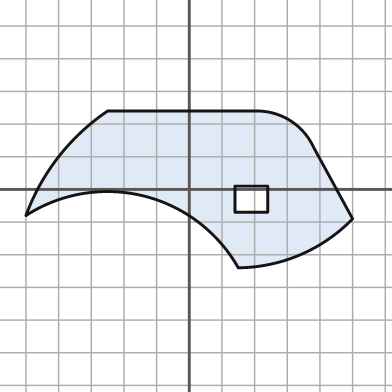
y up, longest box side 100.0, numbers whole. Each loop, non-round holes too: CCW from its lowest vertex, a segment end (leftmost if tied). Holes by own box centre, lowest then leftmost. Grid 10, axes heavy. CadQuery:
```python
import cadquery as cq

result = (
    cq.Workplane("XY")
    .moveTo(15.0, -24.0)
    .threePointArc((34.0, -20.0), (50.0, -9.0))
    .lineTo(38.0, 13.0)
    .threePointArc((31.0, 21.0), (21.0, 24.0))
    .lineTo(-25.0, 24.0)
    .threePointArc((-40.0, 10.0), (-50.0, -8.0))
    .threePointArc((-14.0, -2.0), (15.0, -24.0))
    .close()
    .moveTo(14.0, -7.0)
    .lineTo(24.0, -7.0)
    .lineTo(24.0, 1.0)
    .lineTo(14.0, 1.0)
    .close()
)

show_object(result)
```